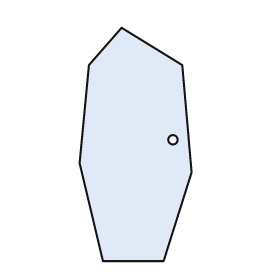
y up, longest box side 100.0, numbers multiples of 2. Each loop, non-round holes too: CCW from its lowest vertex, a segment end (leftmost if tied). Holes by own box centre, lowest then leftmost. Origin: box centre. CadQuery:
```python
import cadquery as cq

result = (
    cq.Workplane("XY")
    .moveTo(-14.0, -50.0)
    .lineTo(12.0, -50.0)
    .lineTo(24.0, -12.0)
    .lineTo(20.0, 34.0)
    .lineTo(-6.0, 50.0)
    .lineTo(-20.0, 34.0)
    .lineTo(-24.0, -8.0)
    .close()
    .moveTo(16.0, 2.0)
    .circle(2.0)
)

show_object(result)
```